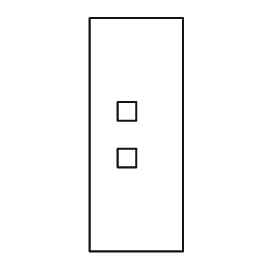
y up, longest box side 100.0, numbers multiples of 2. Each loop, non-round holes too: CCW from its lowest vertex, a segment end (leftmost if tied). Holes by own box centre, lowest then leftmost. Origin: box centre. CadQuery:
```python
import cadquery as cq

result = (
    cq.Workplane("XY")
    .moveTo(-20.0, -50.0)
    .lineTo(20.0, -50.0)
    .lineTo(20.0, 50.0)
    .lineTo(-20.0, 50.0)
    .close()
    .moveTo(-8.0, -14.0)
    .lineTo(0.0, -14.0)
    .lineTo(0.0, -6.0)
    .lineTo(-8.0, -6.0)
    .close()
    .moveTo(-8.0, 6.0)
    .lineTo(0.0, 6.0)
    .lineTo(0.0, 14.0)
    .lineTo(-8.0, 14.0)
    .close()
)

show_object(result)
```